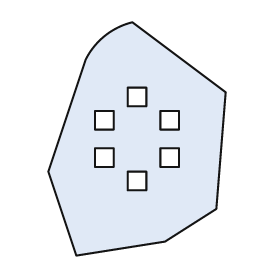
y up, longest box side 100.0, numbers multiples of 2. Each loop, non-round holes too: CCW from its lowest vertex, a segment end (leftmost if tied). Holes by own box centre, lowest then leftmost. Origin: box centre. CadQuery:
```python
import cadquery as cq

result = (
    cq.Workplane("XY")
    .moveTo(-26.0, -50.0)
    .lineTo(12.0, -44.0)
    .lineTo(34.0, -30.0)
    .lineTo(38.0, 20.0)
    .lineTo(-2.0, 50.0)
    .threePointArc((-14.0, 44.0), (-22.0, 34.0))
    .lineTo(-38.0, -14.0)
    .close()
    .moveTo(-4.0, -22.0)
    .lineTo(4.0, -22.0)
    .lineTo(4.0, -14.0)
    .lineTo(-4.0, -14.0)
    .close()
    .moveTo(-18.0, -12.0)
    .lineTo(-10.0, -12.0)
    .lineTo(-10.0, -4.0)
    .lineTo(-18.0, -4.0)
    .close()
    .moveTo(10.0, -12.0)
    .lineTo(18.0, -12.0)
    .lineTo(18.0, -4.0)
    .lineTo(10.0, -4.0)
    .close()
    .moveTo(-18.0, 4.0)
    .lineTo(-10.0, 4.0)
    .lineTo(-10.0, 12.0)
    .lineTo(-18.0, 12.0)
    .close()
    .moveTo(10.0, 4.0)
    .lineTo(18.0, 4.0)
    .lineTo(18.0, 12.0)
    .lineTo(10.0, 12.0)
    .close()
    .moveTo(-4.0, 14.0)
    .lineTo(4.0, 14.0)
    .lineTo(4.0, 22.0)
    .lineTo(-4.0, 22.0)
    .close()
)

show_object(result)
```